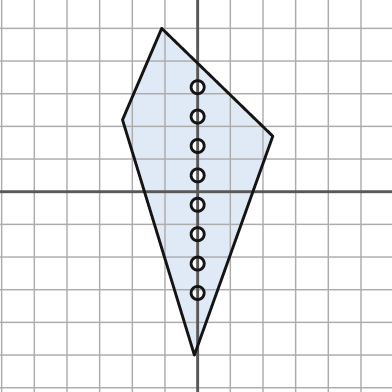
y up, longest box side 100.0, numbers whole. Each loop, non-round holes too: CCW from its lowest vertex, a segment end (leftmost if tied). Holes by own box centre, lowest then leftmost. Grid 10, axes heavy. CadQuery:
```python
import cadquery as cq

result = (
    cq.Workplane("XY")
    .moveTo(-1.0, -50.0)
    .lineTo(23.0, 17.0)
    .lineTo(-11.0, 50.0)
    .lineTo(-23.0, 22.0)
    .close()
    .moveTo(0.0, -31.0)
    .circle(2.0)
    .moveTo(0.0, -22.0)
    .circle(2.0)
    .moveTo(0.0, -13.0)
    .circle(2.0)
    .moveTo(0.0, -4.0)
    .circle(2.0)
    .moveTo(0.0, 5.0)
    .circle(2.0)
    .moveTo(0.0, 14.0)
    .circle(2.0)
    .moveTo(0.0, 23.0)
    .circle(2.0)
    .moveTo(0.0, 32.0)
    .circle(2.0)
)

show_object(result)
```